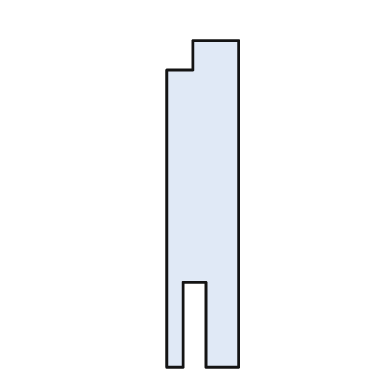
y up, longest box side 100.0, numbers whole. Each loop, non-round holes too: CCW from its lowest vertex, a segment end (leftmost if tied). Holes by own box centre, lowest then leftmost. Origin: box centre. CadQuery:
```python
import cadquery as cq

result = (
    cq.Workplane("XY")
    .moveTo(-11.0, -50.0)
    .lineTo(-6.0, -50.0)
    .lineTo(-6.0, -24.0)
    .lineTo(1.0, -24.0)
    .lineTo(1.0, -50.0)
    .lineTo(11.0, -50.0)
    .lineTo(11.0, 50.0)
    .lineTo(-3.0, 50.0)
    .lineTo(-3.0, 41.0)
    .lineTo(-11.0, 41.0)
    .close()
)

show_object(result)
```